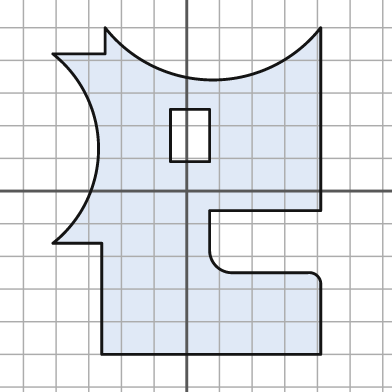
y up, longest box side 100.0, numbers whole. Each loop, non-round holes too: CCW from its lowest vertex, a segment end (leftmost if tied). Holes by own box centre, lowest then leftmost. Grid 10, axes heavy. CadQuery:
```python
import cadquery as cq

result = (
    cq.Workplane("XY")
    .moveTo(-26.0, -50.0)
    .lineTo(41.0, -50.0)
    .lineTo(41.0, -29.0)
    .threePointArc((40.0, -26.0), (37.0, -25.0))
    .lineTo(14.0, -25.0)
    .threePointArc((9.0, -23.0), (7.0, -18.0))
    .lineTo(7.0, -6.0)
    .lineTo(41.0, -6.0)
    .lineTo(41.0, 50.0)
    .threePointArc((8.0, 34.0), (-25.0, 50.0))
    .lineTo(-25.0, 42.0)
    .lineTo(-41.0, 42.0)
    .threePointArc((-27.0, 13.0), (-41.0, -16.0))
    .lineTo(-26.0, -16.0)
    .close()
    .moveTo(-5.0, 9.0)
    .lineTo(7.0, 9.0)
    .lineTo(7.0, 25.0)
    .lineTo(-5.0, 25.0)
    .close()
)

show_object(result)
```